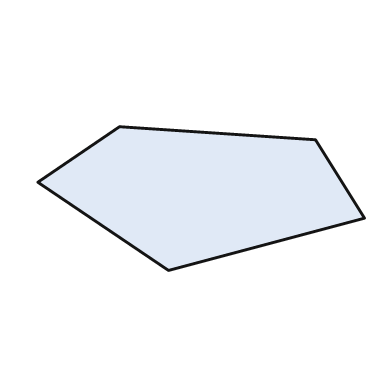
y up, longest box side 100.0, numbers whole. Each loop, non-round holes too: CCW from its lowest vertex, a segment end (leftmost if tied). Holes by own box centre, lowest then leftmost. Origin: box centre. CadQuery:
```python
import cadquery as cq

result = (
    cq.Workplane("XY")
    .moveTo(-10.0, -22.0)
    .lineTo(50.0, -6.0)
    .lineTo(35.0, 18.0)
    .lineTo(-25.0, 22.0)
    .lineTo(-50.0, 5.0)
    .close()
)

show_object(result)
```